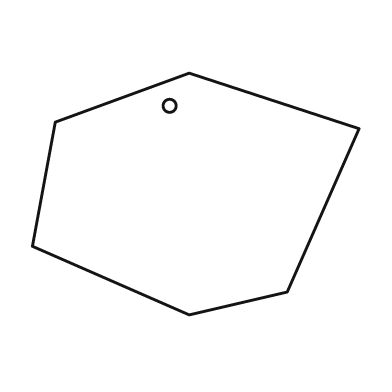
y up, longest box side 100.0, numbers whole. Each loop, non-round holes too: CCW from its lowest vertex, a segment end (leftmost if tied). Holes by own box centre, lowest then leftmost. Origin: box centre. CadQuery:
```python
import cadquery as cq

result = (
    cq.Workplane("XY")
    .moveTo(-2.0, -37.0)
    .lineTo(28.0, -30.0)
    .lineTo(50.0, 20.0)
    .lineTo(-2.0, 37.0)
    .lineTo(-43.0, 22.0)
    .lineTo(-50.0, -16.0)
    .close()
    .moveTo(-8.0, 27.0)
    .circle(2.0)
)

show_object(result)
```